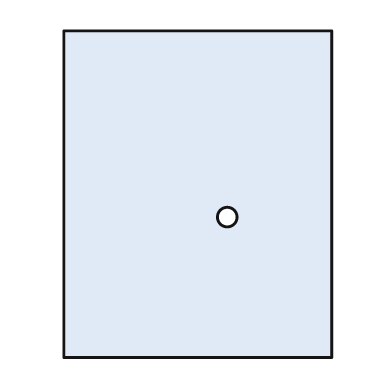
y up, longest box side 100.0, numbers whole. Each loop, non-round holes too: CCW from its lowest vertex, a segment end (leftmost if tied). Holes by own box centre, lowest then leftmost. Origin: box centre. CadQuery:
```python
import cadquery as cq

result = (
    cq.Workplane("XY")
    .moveTo(-41.0, -50.0)
    .lineTo(41.0, -50.0)
    .lineTo(41.0, 50.0)
    .lineTo(-41.0, 50.0)
    .close()
    .moveTo(9.0, -7.0)
    .circle(3.0)
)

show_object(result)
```